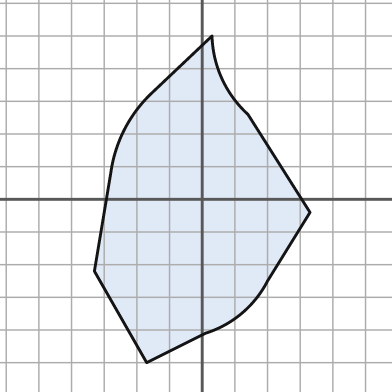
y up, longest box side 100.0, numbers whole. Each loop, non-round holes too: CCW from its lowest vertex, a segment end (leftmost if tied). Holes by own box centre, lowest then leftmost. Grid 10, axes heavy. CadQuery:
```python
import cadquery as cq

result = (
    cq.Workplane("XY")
    .moveTo(-17.0, -50.0)
    .lineTo(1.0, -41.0)
    .threePointArc((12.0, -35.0), (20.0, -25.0))
    .lineTo(33.0, -4.0)
    .lineTo(14.0, 26.0)
    .threePointArc((6.0, 37.0), (3.0, 50.0))
    .lineTo(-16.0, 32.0)
    .threePointArc((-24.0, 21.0), (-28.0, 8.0))
    .lineTo(-33.0, -22.0)
    .close()
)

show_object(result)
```